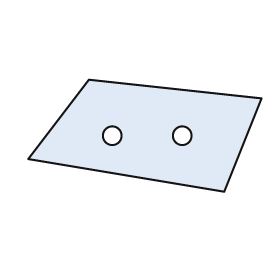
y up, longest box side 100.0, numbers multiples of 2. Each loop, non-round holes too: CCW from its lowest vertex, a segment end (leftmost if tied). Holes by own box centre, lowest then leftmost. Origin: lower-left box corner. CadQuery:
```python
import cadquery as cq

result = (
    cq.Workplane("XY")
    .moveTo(84.0, 0.0)
    .lineTo(100.0, 40.0)
    .lineTo(26.0, 48.0)
    .lineTo(0.0, 14.0)
    .close()
    .moveTo(36.0, 24.0)
    .circle(4.0)
    .moveTo(66.0, 24.0)
    .circle(4.0)
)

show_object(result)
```